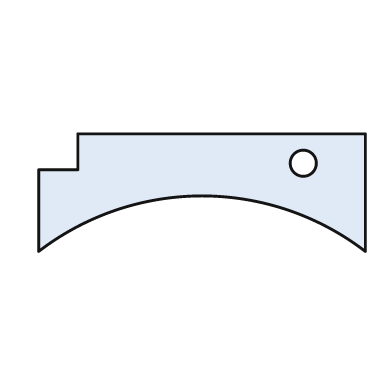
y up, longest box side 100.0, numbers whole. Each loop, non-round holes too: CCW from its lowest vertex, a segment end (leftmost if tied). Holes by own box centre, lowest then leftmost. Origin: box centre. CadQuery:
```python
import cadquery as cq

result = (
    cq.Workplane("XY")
    .moveTo(-50.0, -18.0)
    .threePointArc((0.0, -1.0), (50.0, -18.0))
    .lineTo(50.0, 18.0)
    .lineTo(-38.0, 18.0)
    .lineTo(-38.0, 7.0)
    .lineTo(-50.0, 7.0)
    .close()
    .moveTo(31.0, 9.0)
    .circle(4.0)
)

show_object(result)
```